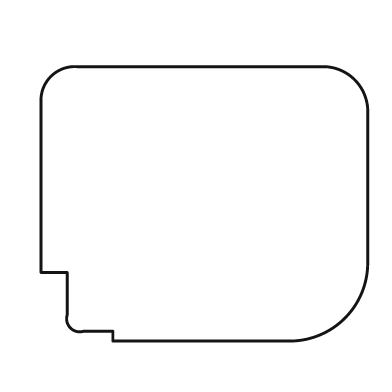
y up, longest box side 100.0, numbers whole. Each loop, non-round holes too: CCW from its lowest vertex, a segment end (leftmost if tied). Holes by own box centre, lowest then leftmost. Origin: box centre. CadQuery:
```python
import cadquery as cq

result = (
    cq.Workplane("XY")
    .moveTo(-28.0, -42.0)
    .lineTo(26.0, -42.0)
    .threePointArc((43.0, -35.0), (50.0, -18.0))
    .lineTo(50.0, 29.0)
    .threePointArc((46.0, 38.0), (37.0, 42.0))
    .lineTo(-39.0, 42.0)
    .threePointArc((-47.0, 39.0), (-50.0, 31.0))
    .lineTo(-50.0, -21.0)
    .lineTo(-42.0, -21.0)
    .lineTo(-42.0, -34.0)
    .threePointArc((-41.0, -38.0), (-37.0, -39.0))
    .lineTo(-28.0, -39.0)
    .close()
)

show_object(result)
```